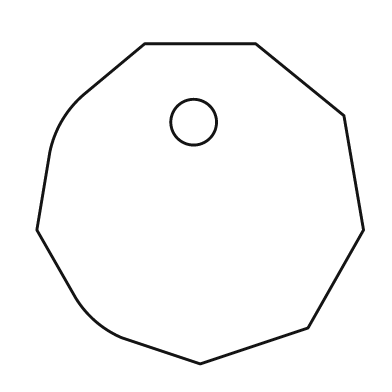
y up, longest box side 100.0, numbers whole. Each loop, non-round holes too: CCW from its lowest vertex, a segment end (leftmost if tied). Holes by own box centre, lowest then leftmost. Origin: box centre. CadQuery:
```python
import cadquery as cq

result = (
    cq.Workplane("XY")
    .moveTo(0.0, -49.0)
    .lineTo(33.0, -38.0)
    .lineTo(50.0, -8.0)
    .lineTo(44.0, 27.0)
    .lineTo(17.0, 49.0)
    .lineTo(-17.0, 49.0)
    .lineTo(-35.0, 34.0)
    .threePointArc((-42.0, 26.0), (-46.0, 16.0))
    .lineTo(-50.0, -8.0)
    .lineTo(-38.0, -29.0)
    .threePointArc((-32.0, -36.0), (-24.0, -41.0))
    .close()
    .moveTo(-2.0, 25.0)
    .circle(7.0)
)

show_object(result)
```